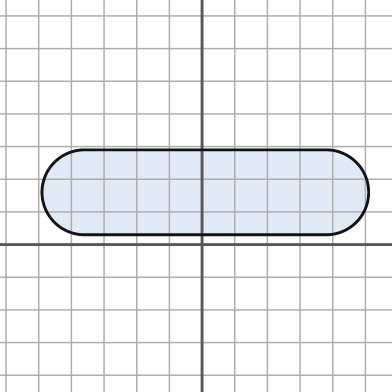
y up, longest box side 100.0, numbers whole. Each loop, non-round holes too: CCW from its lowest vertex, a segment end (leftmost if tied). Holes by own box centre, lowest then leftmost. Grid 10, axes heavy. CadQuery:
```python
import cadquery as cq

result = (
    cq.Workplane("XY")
    .moveTo(-36.0, 3.0)
    .lineTo(38.0, 3.0)
    .threePointArc((51.0, 16.0), (38.0, 29.0))
    .lineTo(-36.0, 29.0)
    .threePointArc((-49.0, 16.0), (-36.0, 3.0))
    .close()
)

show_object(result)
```